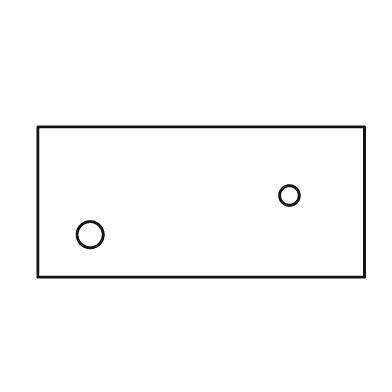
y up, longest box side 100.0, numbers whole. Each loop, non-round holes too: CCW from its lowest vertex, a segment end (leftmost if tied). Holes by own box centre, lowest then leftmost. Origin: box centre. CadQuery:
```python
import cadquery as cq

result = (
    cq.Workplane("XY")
    .moveTo(-50.0, -23.0)
    .lineTo(50.0, -23.0)
    .lineTo(50.0, 23.0)
    .lineTo(-50.0, 23.0)
    .close()
    .moveTo(-34.0, -10.0)
    .circle(4.0)
    .moveTo(27.0, 2.0)
    .circle(3.0)
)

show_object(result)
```